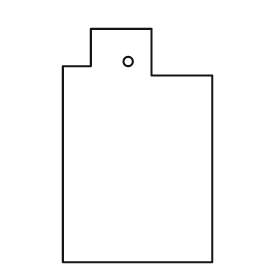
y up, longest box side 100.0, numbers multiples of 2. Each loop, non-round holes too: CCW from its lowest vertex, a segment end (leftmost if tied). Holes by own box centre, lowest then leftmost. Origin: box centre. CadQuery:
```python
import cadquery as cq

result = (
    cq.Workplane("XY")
    .moveTo(-32.0, -50.0)
    .lineTo(32.0, -50.0)
    .lineTo(32.0, 30.0)
    .lineTo(6.0, 30.0)
    .lineTo(6.0, 50.0)
    .lineTo(-20.0, 50.0)
    .lineTo(-20.0, 34.0)
    .lineTo(-32.0, 34.0)
    .close()
    .moveTo(-4.0, 36.0)
    .circle(2.0)
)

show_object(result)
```